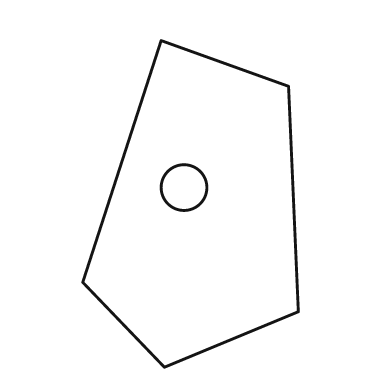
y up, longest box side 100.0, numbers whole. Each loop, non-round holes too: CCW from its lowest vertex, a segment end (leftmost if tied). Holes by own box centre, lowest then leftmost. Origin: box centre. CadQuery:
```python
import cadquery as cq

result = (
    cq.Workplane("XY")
    .moveTo(-8.0, -50.0)
    .lineTo(33.0, -33.0)
    .lineTo(30.0, 36.0)
    .lineTo(-9.0, 50.0)
    .lineTo(-33.0, -24.0)
    .close()
    .moveTo(-2.0, 5.0)
    .circle(7.0)
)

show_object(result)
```